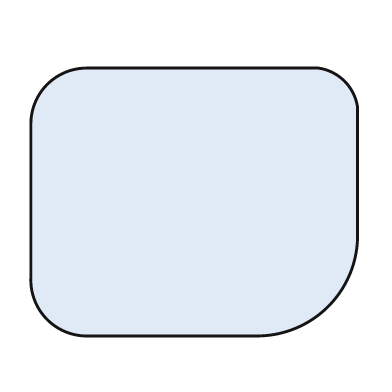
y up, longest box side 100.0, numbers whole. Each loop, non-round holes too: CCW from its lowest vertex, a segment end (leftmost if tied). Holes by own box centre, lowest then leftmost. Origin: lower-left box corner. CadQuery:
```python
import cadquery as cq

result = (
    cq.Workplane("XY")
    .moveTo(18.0, 0.0)
    .lineTo(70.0, 0.0)
    .threePointArc((91.0, 9.0), (100.0, 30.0))
    .lineTo(100.0, 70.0)
    .threePointArc((96.0, 78.0), (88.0, 82.0))
    .lineTo(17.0, 82.0)
    .threePointArc((5.0, 77.0), (0.0, 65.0))
    .lineTo(0.0, 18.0)
    .threePointArc((5.0, 5.0), (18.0, 0.0))
    .close()
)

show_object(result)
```